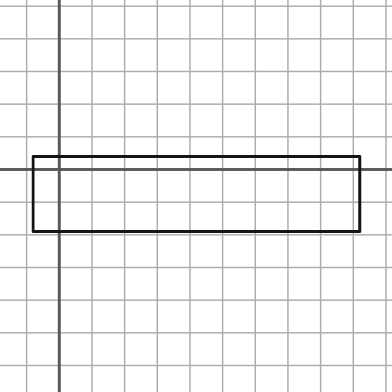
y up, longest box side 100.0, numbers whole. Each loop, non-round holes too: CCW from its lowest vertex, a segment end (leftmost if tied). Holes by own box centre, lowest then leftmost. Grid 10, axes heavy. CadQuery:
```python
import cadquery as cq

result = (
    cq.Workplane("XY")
    .moveTo(-8.0, -19.0)
    .lineTo(92.0, -19.0)
    .lineTo(92.0, 4.0)
    .lineTo(-8.0, 4.0)
    .close()
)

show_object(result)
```